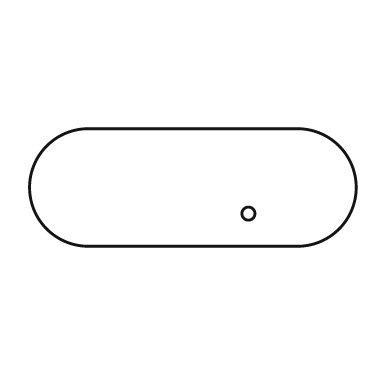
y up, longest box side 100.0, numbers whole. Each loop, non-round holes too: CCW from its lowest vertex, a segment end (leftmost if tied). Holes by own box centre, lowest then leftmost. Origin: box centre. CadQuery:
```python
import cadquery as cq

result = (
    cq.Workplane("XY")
    .moveTo(-32.0, -18.0)
    .lineTo(32.0, -18.0)
    .threePointArc((50.0, 0.0), (32.0, 18.0))
    .lineTo(-32.0, 18.0)
    .threePointArc((-50.0, 0.0), (-32.0, -18.0))
    .close()
    .moveTo(17.0, -8.0)
    .circle(2.0)
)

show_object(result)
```